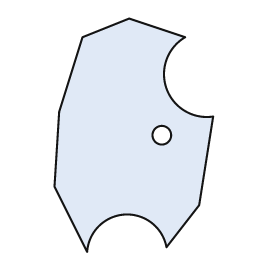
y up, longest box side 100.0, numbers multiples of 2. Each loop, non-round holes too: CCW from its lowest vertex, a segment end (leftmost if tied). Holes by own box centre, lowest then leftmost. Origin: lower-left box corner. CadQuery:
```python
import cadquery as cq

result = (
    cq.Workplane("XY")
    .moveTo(14.0, 0.0)
    .threePointArc((30.0, 16.0), (48.0, 2.0))
    .lineTo(62.0, 20.0)
    .lineTo(68.0, 58.0)
    .threePointArc((48.0, 70.0), (56.0, 92.0))
    .lineTo(32.0, 100.0)
    .lineTo(12.0, 92.0)
    .lineTo(2.0, 60.0)
    .lineTo(0.0, 28.0)
    .close()
    .moveTo(46.0, 50.0)
    .circle(4.0)
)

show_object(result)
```